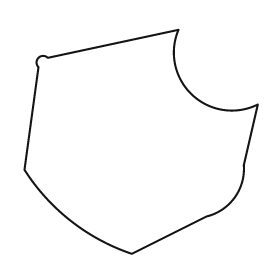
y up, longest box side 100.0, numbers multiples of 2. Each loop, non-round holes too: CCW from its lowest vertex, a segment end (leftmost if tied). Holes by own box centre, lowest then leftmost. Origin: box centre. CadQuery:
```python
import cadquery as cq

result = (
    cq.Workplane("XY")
    .moveTo(-4.0, -48.0)
    .lineTo(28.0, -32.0)
    .threePointArc((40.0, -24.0), (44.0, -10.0))
    .lineTo(50.0, 16.0)
    .threePointArc((22.0, 20.0), (16.0, 48.0))
    .lineTo(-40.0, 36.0)
    .threePointArc((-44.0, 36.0), (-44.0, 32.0))
    .lineTo(-50.0, -12.0)
    .threePointArc((-30.0, -34.0), (-4.0, -48.0))
    .close()
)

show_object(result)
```